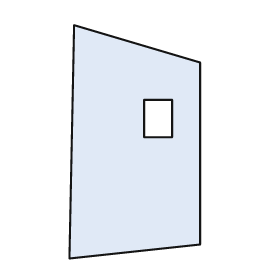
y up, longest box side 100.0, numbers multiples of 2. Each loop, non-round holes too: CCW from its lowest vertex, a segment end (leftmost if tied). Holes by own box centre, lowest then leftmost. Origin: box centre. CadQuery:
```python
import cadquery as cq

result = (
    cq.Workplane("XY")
    .moveTo(-28.0, -50.0)
    .lineTo(28.0, -44.0)
    .lineTo(28.0, 34.0)
    .lineTo(-26.0, 50.0)
    .close()
    .moveTo(4.0, 2.0)
    .lineTo(16.0, 2.0)
    .lineTo(16.0, 18.0)
    .lineTo(4.0, 18.0)
    .close()
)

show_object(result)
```